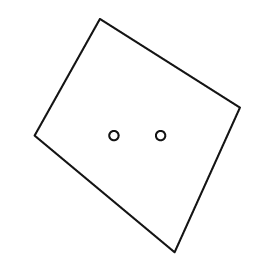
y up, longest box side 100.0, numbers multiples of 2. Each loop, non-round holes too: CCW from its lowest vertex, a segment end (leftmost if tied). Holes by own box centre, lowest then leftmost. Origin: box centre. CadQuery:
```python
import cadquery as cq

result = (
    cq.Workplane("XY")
    .moveTo(16.0, -50.0)
    .lineTo(44.0, 12.0)
    .lineTo(-16.0, 50.0)
    .lineTo(-44.0, 0.0)
    .close()
    .moveTo(-10.0, 0.0)
    .circle(2.0)
    .moveTo(10.0, 0.0)
    .circle(2.0)
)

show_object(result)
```